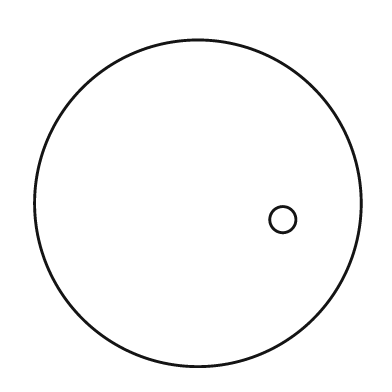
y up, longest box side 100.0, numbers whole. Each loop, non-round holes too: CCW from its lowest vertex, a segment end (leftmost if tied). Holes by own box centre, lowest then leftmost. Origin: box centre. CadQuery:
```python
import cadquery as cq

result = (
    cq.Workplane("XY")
    .moveTo(0.0, 0.0)
    .circle(50.0)
    .moveTo(26.0, -5.0)
    .circle(4.0)
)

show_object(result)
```